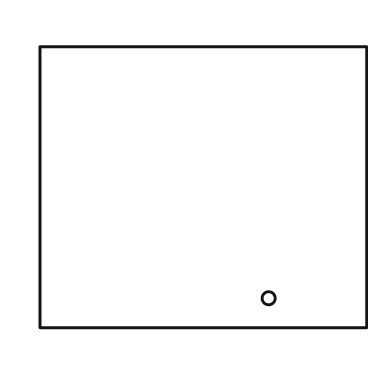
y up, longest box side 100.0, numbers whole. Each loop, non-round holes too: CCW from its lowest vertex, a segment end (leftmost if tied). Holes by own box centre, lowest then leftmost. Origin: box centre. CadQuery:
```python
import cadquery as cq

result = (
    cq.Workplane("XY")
    .moveTo(-50.0, -43.0)
    .lineTo(50.0, -43.0)
    .lineTo(50.0, 43.0)
    .lineTo(-50.0, 43.0)
    .close()
    .moveTo(20.0, -34.0)
    .circle(2.0)
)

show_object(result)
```